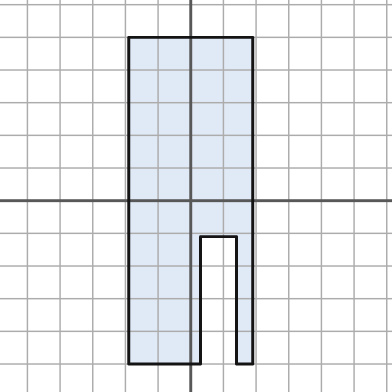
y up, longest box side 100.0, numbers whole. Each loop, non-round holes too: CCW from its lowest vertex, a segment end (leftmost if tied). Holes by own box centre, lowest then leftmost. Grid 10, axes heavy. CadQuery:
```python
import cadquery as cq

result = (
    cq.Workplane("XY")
    .moveTo(-19.0, -50.0)
    .lineTo(3.0, -50.0)
    .lineTo(3.0, -11.0)
    .lineTo(14.0, -11.0)
    .lineTo(14.0, -50.0)
    .lineTo(19.0, -50.0)
    .lineTo(19.0, 50.0)
    .lineTo(-19.0, 50.0)
    .close()
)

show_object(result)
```